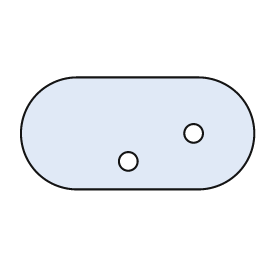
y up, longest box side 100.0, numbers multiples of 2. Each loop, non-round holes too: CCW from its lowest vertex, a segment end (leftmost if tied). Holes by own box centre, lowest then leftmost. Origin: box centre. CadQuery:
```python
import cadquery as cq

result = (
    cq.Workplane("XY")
    .moveTo(-26.0, -24.0)
    .lineTo(26.0, -24.0)
    .threePointArc((50.0, 0.0), (26.0, 24.0))
    .lineTo(-26.0, 24.0)
    .threePointArc((-50.0, 0.0), (-26.0, -24.0))
    .close()
    .moveTo(-4.0, -12.0)
    .circle(4.0)
    .moveTo(24.0, 0.0)
    .circle(4.0)
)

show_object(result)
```